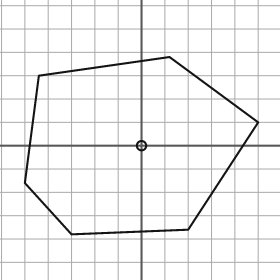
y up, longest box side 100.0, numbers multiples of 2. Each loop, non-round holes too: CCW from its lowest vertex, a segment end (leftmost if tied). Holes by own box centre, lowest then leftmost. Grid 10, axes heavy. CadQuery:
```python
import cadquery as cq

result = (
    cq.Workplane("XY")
    .moveTo(-30.0, -38.0)
    .lineTo(20.0, -36.0)
    .lineTo(50.0, 10.0)
    .lineTo(12.0, 38.0)
    .lineTo(-44.0, 30.0)
    .lineTo(-50.0, -16.0)
    .close()
    .moveTo(0.0, 0.0)
    .circle(2.0)
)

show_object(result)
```